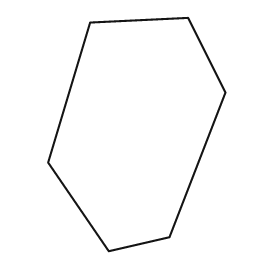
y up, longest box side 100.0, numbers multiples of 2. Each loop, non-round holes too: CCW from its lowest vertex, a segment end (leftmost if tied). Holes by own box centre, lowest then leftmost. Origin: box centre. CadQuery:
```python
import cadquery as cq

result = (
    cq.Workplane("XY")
    .moveTo(-12.0, -50.0)
    .lineTo(14.0, -44.0)
    .lineTo(38.0, 18.0)
    .lineTo(22.0, 50.0)
    .lineTo(-20.0, 48.0)
    .lineTo(-38.0, -12.0)
    .close()
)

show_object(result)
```